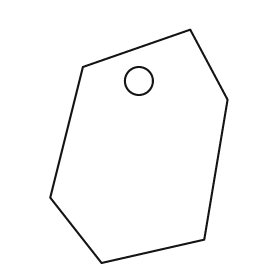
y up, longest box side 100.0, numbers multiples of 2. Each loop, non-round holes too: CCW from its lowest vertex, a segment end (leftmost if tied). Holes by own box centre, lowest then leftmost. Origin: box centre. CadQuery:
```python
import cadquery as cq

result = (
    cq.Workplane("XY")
    .moveTo(-16.0, -50.0)
    .lineTo(28.0, -40.0)
    .lineTo(38.0, 20.0)
    .lineTo(22.0, 50.0)
    .lineTo(-24.0, 34.0)
    .lineTo(-38.0, -22.0)
    .close()
    .moveTo(0.0, 28.0)
    .circle(6.0)
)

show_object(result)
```